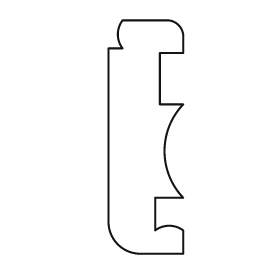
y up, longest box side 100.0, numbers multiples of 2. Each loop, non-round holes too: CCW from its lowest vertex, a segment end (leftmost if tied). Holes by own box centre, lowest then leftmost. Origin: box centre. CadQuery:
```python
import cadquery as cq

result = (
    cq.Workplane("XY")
    .moveTo(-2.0, -50.0)
    .lineTo(16.0, -50.0)
    .lineTo(16.0, -40.0)
    .threePointArc((10.0, -38.0), (4.0, -40.0))
    .lineTo(4.0, -26.0)
    .lineTo(16.0, -26.0)
    .threePointArc((8.0, -6.0), (16.0, 14.0))
    .lineTo(6.0, 14.0)
    .lineTo(6.0, 36.0)
    .lineTo(16.0, 36.0)
    .lineTo(16.0, 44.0)
    .threePointArc((14.0, 48.0), (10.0, 50.0))
    .lineTo(-10.0, 50.0)
    .threePointArc((-12.0, 44.0), (-10.0, 38.0))
    .lineTo(-16.0, 38.0)
    .lineTo(-16.0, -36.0)
    .threePointArc((-12.0, -46.0), (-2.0, -50.0))
    .close()
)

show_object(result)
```